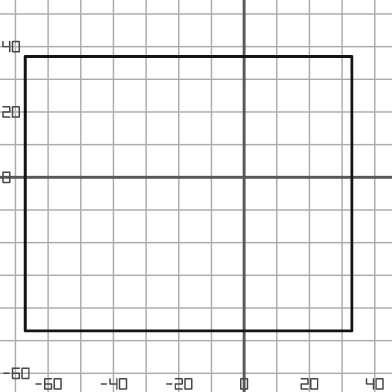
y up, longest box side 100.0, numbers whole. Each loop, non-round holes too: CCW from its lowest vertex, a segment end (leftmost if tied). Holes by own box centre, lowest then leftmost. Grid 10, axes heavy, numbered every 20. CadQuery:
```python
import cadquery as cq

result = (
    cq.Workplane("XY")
    .moveTo(-67.0, -47.0)
    .lineTo(33.0, -47.0)
    .lineTo(33.0, 37.0)
    .lineTo(-67.0, 37.0)
    .close()
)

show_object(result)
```